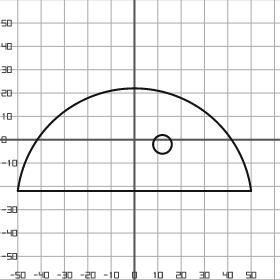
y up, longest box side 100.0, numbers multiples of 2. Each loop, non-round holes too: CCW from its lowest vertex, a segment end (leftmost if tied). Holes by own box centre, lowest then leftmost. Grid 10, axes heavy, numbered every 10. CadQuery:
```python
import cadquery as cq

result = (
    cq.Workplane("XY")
    .moveTo(-50.0, -22.0)
    .lineTo(50.0, -22.0)
    .threePointArc((0.0, 22.0), (-50.0, -22.0))
    .close()
    .moveTo(12.0, -2.0)
    .circle(4.0)
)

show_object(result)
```